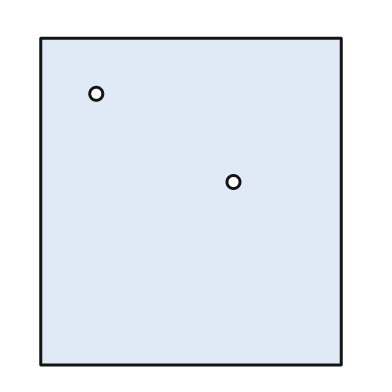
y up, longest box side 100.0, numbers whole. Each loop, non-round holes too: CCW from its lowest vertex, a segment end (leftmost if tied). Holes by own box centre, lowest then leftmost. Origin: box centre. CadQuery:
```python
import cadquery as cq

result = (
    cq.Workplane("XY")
    .moveTo(-46.0, -50.0)
    .lineTo(46.0, -50.0)
    .lineTo(46.0, 50.0)
    .lineTo(-46.0, 50.0)
    .close()
    .moveTo(13.0, 6.0)
    .circle(2.0)
    .moveTo(-29.0, 33.0)
    .circle(2.0)
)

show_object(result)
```